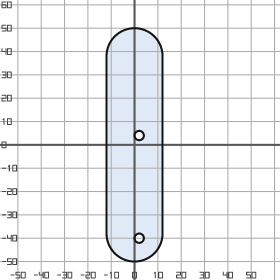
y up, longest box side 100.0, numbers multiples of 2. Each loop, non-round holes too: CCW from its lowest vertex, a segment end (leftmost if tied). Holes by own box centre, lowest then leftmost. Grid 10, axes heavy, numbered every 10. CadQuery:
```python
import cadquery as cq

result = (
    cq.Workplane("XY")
    .moveTo(-12.0, -38.0)
    .threePointArc((0.0, -50.0), (12.0, -38.0))
    .lineTo(12.0, 38.0)
    .threePointArc((0.0, 50.0), (-12.0, 38.0))
    .close()
    .moveTo(2.0, -40.0)
    .circle(2.0)
    .moveTo(2.0, 4.0)
    .circle(2.0)
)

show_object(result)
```